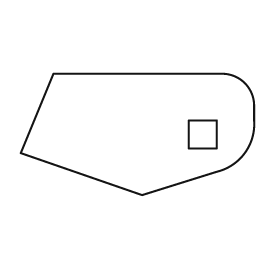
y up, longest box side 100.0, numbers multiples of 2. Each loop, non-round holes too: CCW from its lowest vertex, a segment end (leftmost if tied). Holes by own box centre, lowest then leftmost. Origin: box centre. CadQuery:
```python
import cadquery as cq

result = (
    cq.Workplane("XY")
    .moveTo(2.0, -26.0)
    .lineTo(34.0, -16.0)
    .threePointArc((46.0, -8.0), (50.0, 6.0))
    .lineTo(50.0, 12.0)
    .threePointArc((46.0, 22.0), (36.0, 26.0))
    .lineTo(-36.0, 26.0)
    .lineTo(-50.0, -8.0)
    .close()
    .moveTo(22.0, -6.0)
    .lineTo(34.0, -6.0)
    .lineTo(34.0, 6.0)
    .lineTo(22.0, 6.0)
    .close()
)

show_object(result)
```